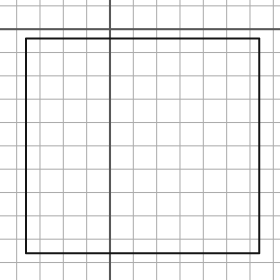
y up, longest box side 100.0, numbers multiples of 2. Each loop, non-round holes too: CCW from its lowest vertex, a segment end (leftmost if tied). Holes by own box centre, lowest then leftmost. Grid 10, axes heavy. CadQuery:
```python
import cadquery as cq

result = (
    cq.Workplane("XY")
    .moveTo(-36.0, -96.0)
    .lineTo(64.0, -96.0)
    .lineTo(64.0, -4.0)
    .lineTo(-36.0, -4.0)
    .close()
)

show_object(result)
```